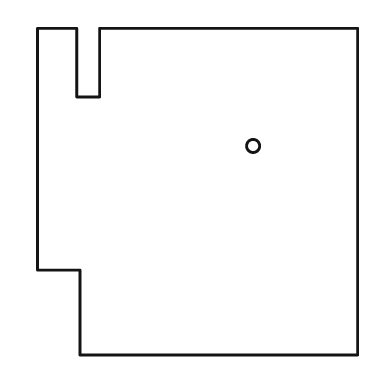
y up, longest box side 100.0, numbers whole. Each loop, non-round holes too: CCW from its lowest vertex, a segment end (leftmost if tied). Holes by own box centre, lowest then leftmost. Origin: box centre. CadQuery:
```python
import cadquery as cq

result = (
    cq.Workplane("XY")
    .moveTo(-36.0, -50.0)
    .lineTo(49.0, -50.0)
    .lineTo(49.0, 50.0)
    .lineTo(-30.0, 50.0)
    .lineTo(-30.0, 29.0)
    .lineTo(-37.0, 29.0)
    .lineTo(-37.0, 50.0)
    .lineTo(-49.0, 50.0)
    .lineTo(-49.0, -24.0)
    .lineTo(-36.0, -24.0)
    .close()
    .moveTo(17.0, 14.0)
    .circle(2.0)
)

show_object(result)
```